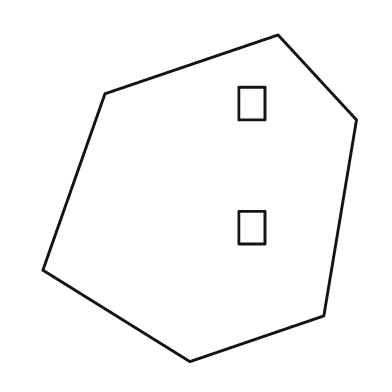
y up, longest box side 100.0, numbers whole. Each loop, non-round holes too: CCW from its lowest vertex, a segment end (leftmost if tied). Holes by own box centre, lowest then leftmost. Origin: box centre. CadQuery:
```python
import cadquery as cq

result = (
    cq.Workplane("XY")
    .moveTo(-3.0, -50.0)
    .lineTo(38.0, -36.0)
    .lineTo(48.0, 24.0)
    .lineTo(24.0, 50.0)
    .lineTo(-29.0, 32.0)
    .lineTo(-48.0, -22.0)
    .close()
    .moveTo(12.0, -14.0)
    .lineTo(20.0, -14.0)
    .lineTo(20.0, -4.0)
    .lineTo(12.0, -4.0)
    .close()
    .moveTo(12.0, 24.0)
    .lineTo(20.0, 24.0)
    .lineTo(20.0, 34.0)
    .lineTo(12.0, 34.0)
    .close()
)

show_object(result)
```